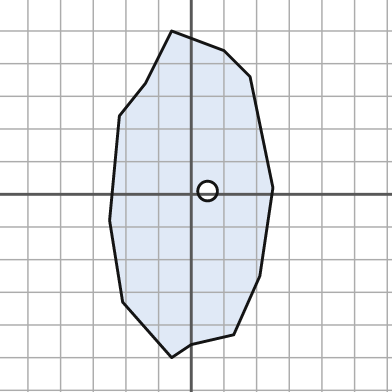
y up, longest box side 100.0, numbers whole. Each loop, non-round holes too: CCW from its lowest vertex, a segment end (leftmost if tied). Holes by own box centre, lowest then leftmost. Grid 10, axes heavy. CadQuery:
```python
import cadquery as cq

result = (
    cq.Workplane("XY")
    .moveTo(-6.0, -50.0)
    .lineTo(0.0, -46.0)
    .lineTo(13.0, -43.0)
    .lineTo(21.0, -25.0)
    .lineTo(25.0, 2.0)
    .lineTo(18.0, 36.0)
    .lineTo(10.0, 44.0)
    .lineTo(-6.0, 50.0)
    .lineTo(-14.0, 34.0)
    .lineTo(-22.0, 24.0)
    .lineTo(-25.0, -8.0)
    .lineTo(-21.0, -33.0)
    .close()
    .moveTo(5.0, 1.0)
    .circle(3.0)
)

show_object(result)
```